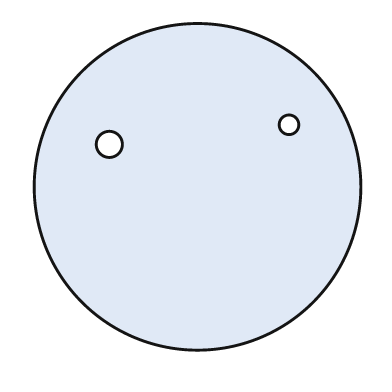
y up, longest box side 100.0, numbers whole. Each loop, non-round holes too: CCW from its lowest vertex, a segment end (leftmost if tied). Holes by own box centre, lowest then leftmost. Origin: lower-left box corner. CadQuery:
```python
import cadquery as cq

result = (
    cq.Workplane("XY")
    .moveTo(50.0, 50.0)
    .circle(50.0)
    .moveTo(23.0, 63.0)
    .circle(4.0)
    .moveTo(78.0, 69.0)
    .circle(3.0)
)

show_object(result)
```